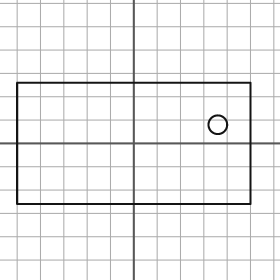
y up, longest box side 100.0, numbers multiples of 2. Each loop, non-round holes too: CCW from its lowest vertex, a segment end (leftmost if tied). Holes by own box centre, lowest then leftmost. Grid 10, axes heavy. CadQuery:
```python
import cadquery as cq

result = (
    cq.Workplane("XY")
    .moveTo(-50.0, -26.0)
    .lineTo(50.0, -26.0)
    .lineTo(50.0, 26.0)
    .lineTo(-50.0, 26.0)
    .close()
    .moveTo(36.0, 8.0)
    .circle(4.0)
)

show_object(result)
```